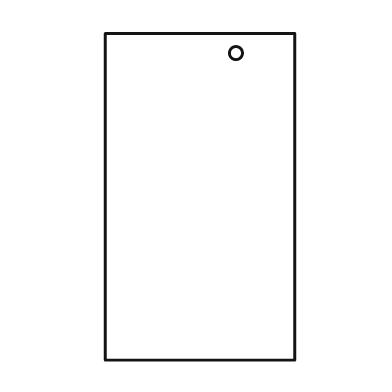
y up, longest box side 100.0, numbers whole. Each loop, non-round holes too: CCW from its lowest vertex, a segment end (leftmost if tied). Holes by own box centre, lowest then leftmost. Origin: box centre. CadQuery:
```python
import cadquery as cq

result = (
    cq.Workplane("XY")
    .moveTo(-29.0, -50.0)
    .lineTo(29.0, -50.0)
    .lineTo(29.0, 50.0)
    .lineTo(-29.0, 50.0)
    .close()
    .moveTo(11.0, 44.0)
    .circle(2.0)
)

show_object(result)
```